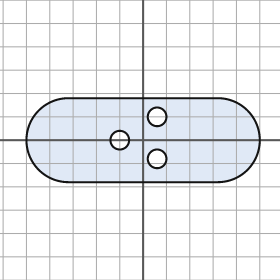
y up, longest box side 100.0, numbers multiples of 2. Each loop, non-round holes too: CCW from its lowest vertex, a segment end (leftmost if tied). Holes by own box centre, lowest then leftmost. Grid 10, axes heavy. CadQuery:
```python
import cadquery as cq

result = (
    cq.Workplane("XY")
    .moveTo(-32.0, -18.0)
    .lineTo(32.0, -18.0)
    .threePointArc((50.0, 0.0), (32.0, 18.0))
    .lineTo(-32.0, 18.0)
    .threePointArc((-50.0, 0.0), (-32.0, -18.0))
    .close()
    .moveTo(6.0, -8.0)
    .circle(4.0)
    .moveTo(-10.0, 0.0)
    .circle(4.0)
    .moveTo(6.0, 10.0)
    .circle(4.0)
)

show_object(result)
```